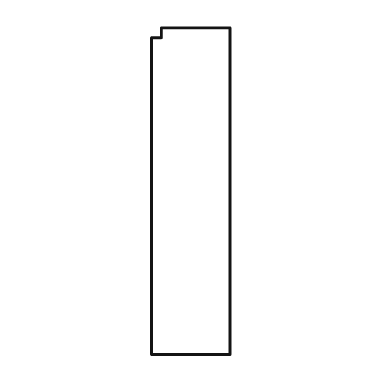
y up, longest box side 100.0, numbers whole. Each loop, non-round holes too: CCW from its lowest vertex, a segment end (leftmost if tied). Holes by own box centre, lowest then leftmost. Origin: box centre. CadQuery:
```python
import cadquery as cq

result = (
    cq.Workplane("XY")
    .moveTo(-12.0, -50.0)
    .lineTo(12.0, -50.0)
    .lineTo(12.0, 50.0)
    .lineTo(-9.0, 50.0)
    .lineTo(-9.0, 47.0)
    .lineTo(-12.0, 47.0)
    .close()
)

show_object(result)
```